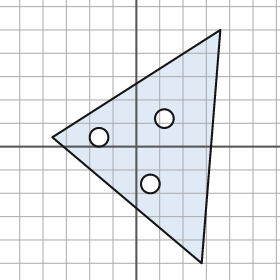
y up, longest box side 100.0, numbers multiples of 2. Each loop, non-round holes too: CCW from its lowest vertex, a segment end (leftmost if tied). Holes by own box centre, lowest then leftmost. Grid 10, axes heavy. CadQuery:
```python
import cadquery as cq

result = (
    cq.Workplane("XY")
    .moveTo(28.0, -50.0)
    .lineTo(36.0, 50.0)
    .lineTo(-36.0, 4.0)
    .close()
    .moveTo(6.0, -16.0)
    .circle(4.0)
    .moveTo(-16.0, 4.0)
    .circle(4.0)
    .moveTo(12.0, 12.0)
    .circle(4.0)
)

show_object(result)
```